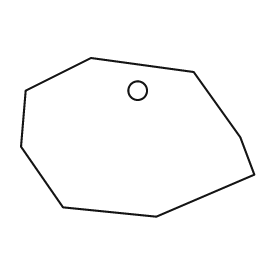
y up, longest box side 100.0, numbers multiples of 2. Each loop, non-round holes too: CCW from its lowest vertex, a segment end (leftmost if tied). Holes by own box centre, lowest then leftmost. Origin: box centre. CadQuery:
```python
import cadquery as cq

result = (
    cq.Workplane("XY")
    .moveTo(8.0, -34.0)
    .lineTo(50.0, -16.0)
    .lineTo(44.0, 0.0)
    .lineTo(24.0, 28.0)
    .lineTo(-20.0, 34.0)
    .lineTo(-48.0, 20.0)
    .lineTo(-50.0, -4.0)
    .lineTo(-32.0, -30.0)
    .close()
    .moveTo(0.0, 20.0)
    .circle(4.0)
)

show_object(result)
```